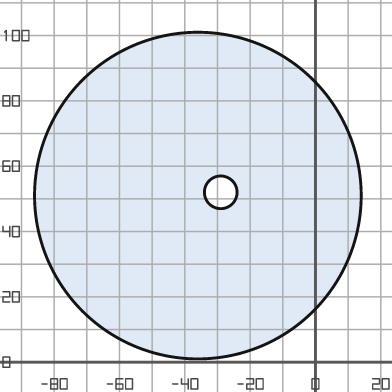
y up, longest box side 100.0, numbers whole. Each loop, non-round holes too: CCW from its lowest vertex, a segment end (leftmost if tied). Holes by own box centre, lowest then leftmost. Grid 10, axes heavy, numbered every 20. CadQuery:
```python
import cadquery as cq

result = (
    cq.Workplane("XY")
    .moveTo(-36.0, 51.0)
    .circle(50.0)
    .moveTo(-29.0, 52.0)
    .circle(5.0)
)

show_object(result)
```